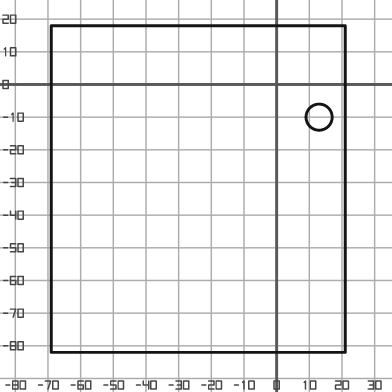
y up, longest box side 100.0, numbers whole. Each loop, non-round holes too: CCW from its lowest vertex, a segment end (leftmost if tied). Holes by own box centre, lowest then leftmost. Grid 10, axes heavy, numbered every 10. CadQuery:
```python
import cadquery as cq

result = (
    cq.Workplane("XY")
    .moveTo(-69.0, -82.0)
    .lineTo(21.0, -82.0)
    .lineTo(21.0, 18.0)
    .lineTo(-69.0, 18.0)
    .close()
    .moveTo(13.0, -10.0)
    .circle(4.0)
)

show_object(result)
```